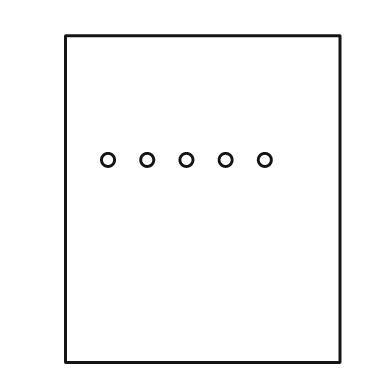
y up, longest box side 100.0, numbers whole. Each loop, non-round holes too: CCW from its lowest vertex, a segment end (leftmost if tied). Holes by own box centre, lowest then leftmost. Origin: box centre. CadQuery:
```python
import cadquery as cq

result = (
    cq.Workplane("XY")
    .moveTo(-42.0, -50.0)
    .lineTo(42.0, -50.0)
    .lineTo(42.0, 50.0)
    .lineTo(-42.0, 50.0)
    .close()
    .moveTo(-29.0, 12.0)
    .circle(2.0)
    .moveTo(-17.0, 12.0)
    .circle(2.0)
    .moveTo(-5.0, 12.0)
    .circle(2.0)
    .moveTo(7.0, 12.0)
    .circle(2.0)
    .moveTo(19.0, 12.0)
    .circle(2.0)
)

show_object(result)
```